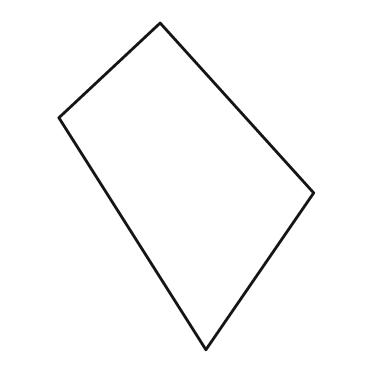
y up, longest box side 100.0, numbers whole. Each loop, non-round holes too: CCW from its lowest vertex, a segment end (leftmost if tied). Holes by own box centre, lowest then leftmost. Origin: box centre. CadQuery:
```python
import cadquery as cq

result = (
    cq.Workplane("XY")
    .moveTo(6.0, -50.0)
    .lineTo(39.0, -2.0)
    .lineTo(-8.0, 50.0)
    .lineTo(-39.0, 21.0)
    .close()
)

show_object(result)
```